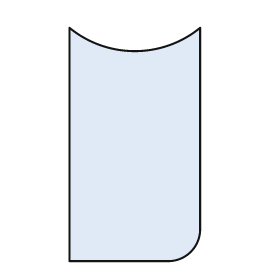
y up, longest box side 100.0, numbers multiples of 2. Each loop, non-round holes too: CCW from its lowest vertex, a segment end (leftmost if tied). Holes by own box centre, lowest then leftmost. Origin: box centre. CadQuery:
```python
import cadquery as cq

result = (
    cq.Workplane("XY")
    .moveTo(-28.0, -50.0)
    .lineTo(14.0, -50.0)
    .threePointArc((24.0, -46.0), (28.0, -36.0))
    .lineTo(28.0, 50.0)
    .threePointArc((0.0, 40.0), (-28.0, 50.0))
    .close()
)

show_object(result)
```